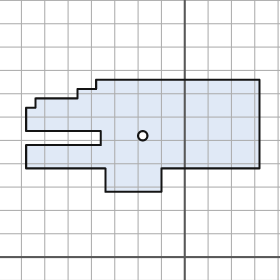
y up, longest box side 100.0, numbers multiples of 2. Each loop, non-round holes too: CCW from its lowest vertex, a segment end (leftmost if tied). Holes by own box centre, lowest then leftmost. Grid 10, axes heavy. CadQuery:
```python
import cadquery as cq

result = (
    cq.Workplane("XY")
    .moveTo(-34.0, 28.0)
    .lineTo(-10.0, 28.0)
    .lineTo(-10.0, 38.0)
    .lineTo(32.0, 38.0)
    .lineTo(32.0, 76.0)
    .lineTo(-38.0, 76.0)
    .lineTo(-38.0, 72.0)
    .lineTo(-46.0, 72.0)
    .lineTo(-46.0, 68.0)
    .lineTo(-64.0, 68.0)
    .lineTo(-64.0, 64.0)
    .lineTo(-68.0, 64.0)
    .lineTo(-68.0, 54.0)
    .lineTo(-36.0, 54.0)
    .lineTo(-36.0, 48.0)
    .lineTo(-68.0, 48.0)
    .lineTo(-68.0, 38.0)
    .lineTo(-34.0, 38.0)
    .close()
    .moveTo(-18.0, 52.0)
    .circle(2.0)
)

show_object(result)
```